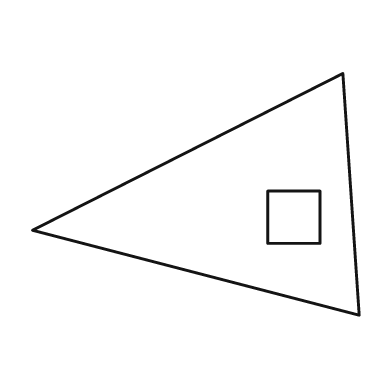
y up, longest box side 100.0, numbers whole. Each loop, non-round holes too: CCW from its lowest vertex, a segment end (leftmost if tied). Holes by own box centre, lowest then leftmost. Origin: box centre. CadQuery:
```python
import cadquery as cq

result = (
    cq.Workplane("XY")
    .moveTo(50.0, -37.0)
    .lineTo(45.0, 37.0)
    .lineTo(-50.0, -11.0)
    .close()
    .moveTo(22.0, -15.0)
    .lineTo(38.0, -15.0)
    .lineTo(38.0, 1.0)
    .lineTo(22.0, 1.0)
    .close()
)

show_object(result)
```